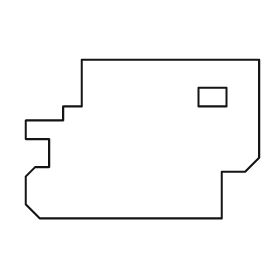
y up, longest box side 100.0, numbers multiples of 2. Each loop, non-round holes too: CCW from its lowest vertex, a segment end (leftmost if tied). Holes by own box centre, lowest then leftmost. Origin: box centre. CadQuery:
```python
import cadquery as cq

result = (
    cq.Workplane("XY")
    .moveTo(-44.0, -34.0)
    .lineTo(34.0, -34.0)
    .lineTo(34.0, -14.0)
    .lineTo(44.0, -14.0)
    .lineTo(50.0, -8.0)
    .lineTo(50.0, 34.0)
    .lineTo(-26.0, 34.0)
    .lineTo(-26.0, 14.0)
    .lineTo(-34.0, 14.0)
    .lineTo(-34.0, 8.0)
    .lineTo(-50.0, 8.0)
    .lineTo(-50.0, 0.0)
    .lineTo(-40.0, 0.0)
    .lineTo(-40.0, -12.0)
    .lineTo(-46.0, -12.0)
    .lineTo(-50.0, -16.0)
    .lineTo(-50.0, -28.0)
    .close()
    .moveTo(24.0, 14.0)
    .lineTo(36.0, 14.0)
    .lineTo(36.0, 22.0)
    .lineTo(24.0, 22.0)
    .close()
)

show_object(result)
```